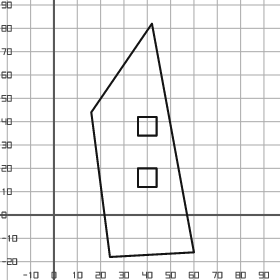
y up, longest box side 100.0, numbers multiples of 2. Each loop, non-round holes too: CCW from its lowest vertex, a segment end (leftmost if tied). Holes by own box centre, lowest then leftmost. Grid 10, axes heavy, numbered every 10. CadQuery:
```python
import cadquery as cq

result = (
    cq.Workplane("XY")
    .moveTo(24.0, -18.0)
    .lineTo(60.0, -16.0)
    .lineTo(42.0, 82.0)
    .lineTo(16.0, 44.0)
    .close()
    .moveTo(36.0, 12.0)
    .lineTo(44.0, 12.0)
    .lineTo(44.0, 20.0)
    .lineTo(36.0, 20.0)
    .close()
    .moveTo(36.0, 34.0)
    .lineTo(44.0, 34.0)
    .lineTo(44.0, 42.0)
    .lineTo(36.0, 42.0)
    .close()
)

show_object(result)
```